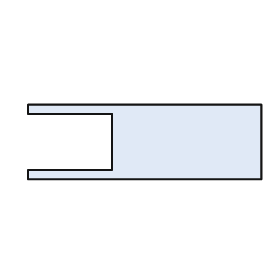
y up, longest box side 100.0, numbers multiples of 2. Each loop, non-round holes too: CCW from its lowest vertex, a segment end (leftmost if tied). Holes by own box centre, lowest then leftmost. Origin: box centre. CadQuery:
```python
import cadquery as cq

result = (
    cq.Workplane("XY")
    .moveTo(-50.0, -16.0)
    .lineTo(50.0, -16.0)
    .lineTo(50.0, 16.0)
    .lineTo(-50.0, 16.0)
    .lineTo(-50.0, 12.0)
    .lineTo(-14.0, 12.0)
    .lineTo(-14.0, -12.0)
    .lineTo(-50.0, -12.0)
    .close()
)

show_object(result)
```